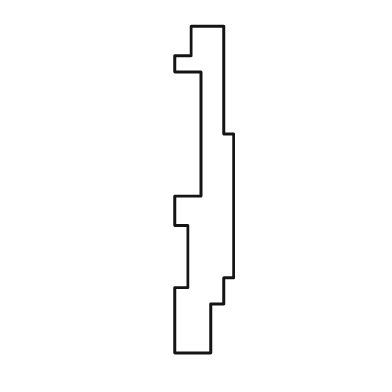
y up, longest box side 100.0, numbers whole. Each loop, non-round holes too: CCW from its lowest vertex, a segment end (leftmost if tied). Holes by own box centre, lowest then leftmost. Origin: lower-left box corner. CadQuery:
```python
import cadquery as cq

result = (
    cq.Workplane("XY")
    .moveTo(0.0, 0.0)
    .lineTo(11.0, 0.0)
    .lineTo(11.0, 15.0)
    .lineTo(15.0, 15.0)
    .lineTo(15.0, 23.0)
    .lineTo(18.0, 23.0)
    .lineTo(18.0, 67.0)
    .lineTo(15.0, 67.0)
    .lineTo(15.0, 100.0)
    .lineTo(5.0, 100.0)
    .lineTo(5.0, 91.0)
    .lineTo(0.0, 91.0)
    .lineTo(0.0, 86.0)
    .lineTo(8.0, 86.0)
    .lineTo(8.0, 48.0)
    .lineTo(0.0, 48.0)
    .lineTo(0.0, 39.0)
    .lineTo(4.0, 39.0)
    .lineTo(4.0, 20.0)
    .lineTo(0.0, 20.0)
    .close()
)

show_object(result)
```